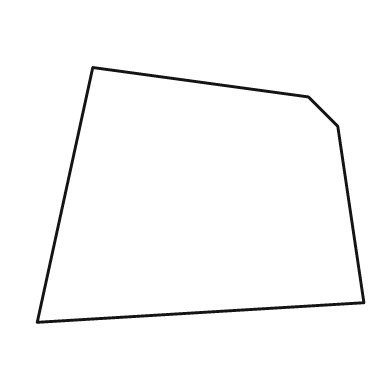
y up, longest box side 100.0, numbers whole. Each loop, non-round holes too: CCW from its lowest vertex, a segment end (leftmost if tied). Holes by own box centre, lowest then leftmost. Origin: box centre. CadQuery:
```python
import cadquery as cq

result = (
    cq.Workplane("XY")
    .moveTo(-50.0, -39.0)
    .lineTo(50.0, -33.0)
    .lineTo(42.0, 21.0)
    .lineTo(33.0, 30.0)
    .lineTo(-33.0, 39.0)
    .close()
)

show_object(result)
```